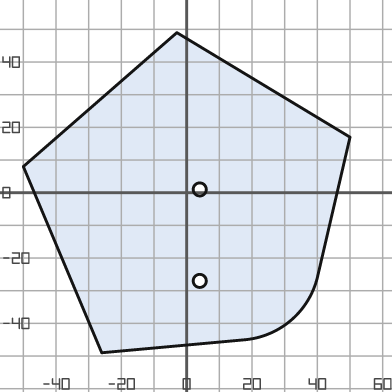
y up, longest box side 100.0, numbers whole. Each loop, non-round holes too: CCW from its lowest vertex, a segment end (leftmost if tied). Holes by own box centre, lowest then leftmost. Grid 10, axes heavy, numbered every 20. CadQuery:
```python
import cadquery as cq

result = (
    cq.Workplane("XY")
    .moveTo(-26.0, -49.0)
    .lineTo(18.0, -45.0)
    .threePointArc((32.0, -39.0), (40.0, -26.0))
    .lineTo(50.0, 17.0)
    .lineTo(-3.0, 49.0)
    .lineTo(-50.0, 8.0)
    .close()
    .moveTo(4.0, -27.0)
    .circle(2.0)
    .moveTo(4.0, 1.0)
    .circle(2.0)
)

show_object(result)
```